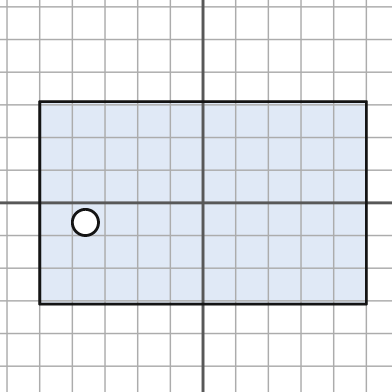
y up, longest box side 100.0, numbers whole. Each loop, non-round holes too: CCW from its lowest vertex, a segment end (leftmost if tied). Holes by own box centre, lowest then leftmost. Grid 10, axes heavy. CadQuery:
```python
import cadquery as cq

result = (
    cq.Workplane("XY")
    .moveTo(-50.0, -31.0)
    .lineTo(50.0, -31.0)
    .lineTo(50.0, 31.0)
    .lineTo(-50.0, 31.0)
    .close()
    .moveTo(-36.0, -6.0)
    .circle(4.0)
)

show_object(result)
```